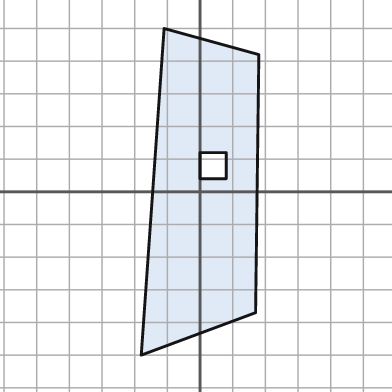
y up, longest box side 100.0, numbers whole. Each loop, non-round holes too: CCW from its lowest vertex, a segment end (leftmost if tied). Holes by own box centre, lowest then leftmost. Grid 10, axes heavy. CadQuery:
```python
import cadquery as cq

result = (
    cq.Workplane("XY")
    .moveTo(-18.0, -50.0)
    .lineTo(17.0, -37.0)
    .lineTo(18.0, 42.0)
    .lineTo(-11.0, 50.0)
    .close()
    .moveTo(0.0, 4.0)
    .lineTo(8.0, 4.0)
    .lineTo(8.0, 12.0)
    .lineTo(0.0, 12.0)
    .close()
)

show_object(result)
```